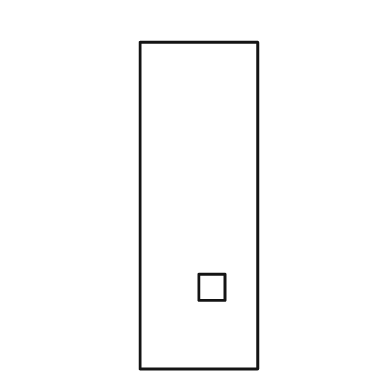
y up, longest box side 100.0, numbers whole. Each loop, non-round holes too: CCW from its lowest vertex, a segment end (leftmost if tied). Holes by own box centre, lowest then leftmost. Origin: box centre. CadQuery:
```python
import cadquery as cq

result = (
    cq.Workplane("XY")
    .moveTo(-18.0, -50.0)
    .lineTo(18.0, -50.0)
    .lineTo(18.0, 50.0)
    .lineTo(-18.0, 50.0)
    .close()
    .moveTo(0.0, -29.0)
    .lineTo(8.0, -29.0)
    .lineTo(8.0, -21.0)
    .lineTo(0.0, -21.0)
    .close()
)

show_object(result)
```